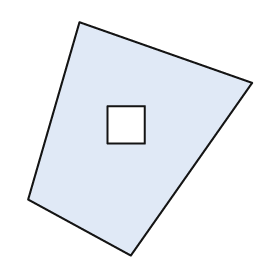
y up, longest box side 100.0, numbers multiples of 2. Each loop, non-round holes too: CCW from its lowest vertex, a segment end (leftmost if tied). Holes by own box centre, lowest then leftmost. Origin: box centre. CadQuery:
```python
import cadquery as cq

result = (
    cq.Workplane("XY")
    .moveTo(-4.0, -50.0)
    .lineTo(48.0, 24.0)
    .lineTo(-26.0, 50.0)
    .lineTo(-48.0, -26.0)
    .close()
    .moveTo(-14.0, -2.0)
    .lineTo(2.0, -2.0)
    .lineTo(2.0, 14.0)
    .lineTo(-14.0, 14.0)
    .close()
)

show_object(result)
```